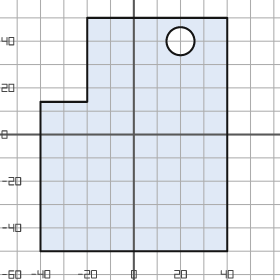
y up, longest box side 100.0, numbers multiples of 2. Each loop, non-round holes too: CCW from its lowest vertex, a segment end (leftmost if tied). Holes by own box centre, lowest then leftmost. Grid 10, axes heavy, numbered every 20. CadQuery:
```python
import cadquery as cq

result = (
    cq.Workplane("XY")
    .moveTo(-40.0, -50.0)
    .lineTo(40.0, -50.0)
    .lineTo(40.0, 50.0)
    .lineTo(-20.0, 50.0)
    .lineTo(-20.0, 14.0)
    .lineTo(-40.0, 14.0)
    .close()
    .moveTo(20.0, 40.0)
    .circle(6.0)
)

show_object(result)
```